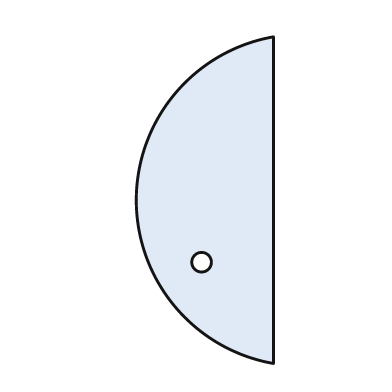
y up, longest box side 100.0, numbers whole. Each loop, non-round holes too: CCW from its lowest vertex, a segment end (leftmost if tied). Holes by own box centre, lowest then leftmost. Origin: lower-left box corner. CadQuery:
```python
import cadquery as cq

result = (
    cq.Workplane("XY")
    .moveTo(42.0, 0.0)
    .lineTo(42.0, 100.0)
    .threePointArc((0.0, 50.0), (42.0, 0.0))
    .close()
    .moveTo(20.0, 31.0)
    .circle(3.0)
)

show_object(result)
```